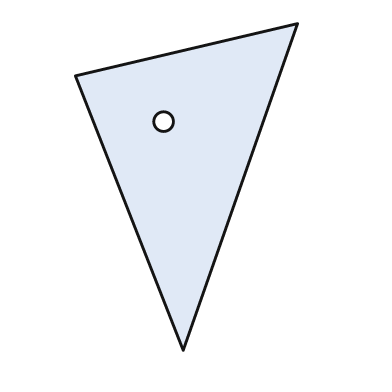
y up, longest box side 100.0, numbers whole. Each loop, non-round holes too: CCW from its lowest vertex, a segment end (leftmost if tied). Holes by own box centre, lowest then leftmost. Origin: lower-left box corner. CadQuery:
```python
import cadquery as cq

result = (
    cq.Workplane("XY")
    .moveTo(33.0, 0.0)
    .lineTo(68.0, 100.0)
    .lineTo(0.0, 84.0)
    .close()
    .moveTo(27.0, 70.0)
    .circle(3.0)
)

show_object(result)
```